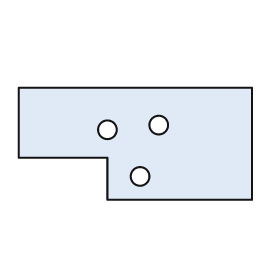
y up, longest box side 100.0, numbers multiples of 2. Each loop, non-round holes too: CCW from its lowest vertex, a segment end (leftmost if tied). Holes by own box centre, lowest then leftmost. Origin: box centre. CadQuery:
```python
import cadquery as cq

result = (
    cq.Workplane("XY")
    .moveTo(-12.0, -24.0)
    .lineTo(50.0, -24.0)
    .lineTo(50.0, 24.0)
    .lineTo(-50.0, 24.0)
    .lineTo(-50.0, -6.0)
    .lineTo(-12.0, -6.0)
    .close()
    .moveTo(2.0, -14.0)
    .circle(4.0)
    .moveTo(-12.0, 6.0)
    .circle(4.0)
    .moveTo(10.0, 8.0)
    .circle(4.0)
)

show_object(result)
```